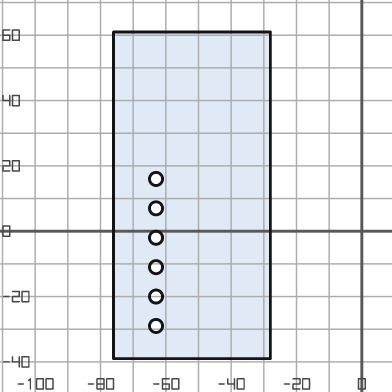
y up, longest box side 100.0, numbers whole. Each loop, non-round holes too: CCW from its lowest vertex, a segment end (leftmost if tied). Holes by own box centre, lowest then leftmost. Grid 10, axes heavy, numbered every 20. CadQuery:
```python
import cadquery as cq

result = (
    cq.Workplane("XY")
    .moveTo(-76.0, -39.0)
    .lineTo(-28.0, -39.0)
    .lineTo(-28.0, 61.0)
    .lineTo(-76.0, 61.0)
    .close()
    .moveTo(-63.0, -29.0)
    .circle(2.0)
    .moveTo(-63.0, -20.0)
    .circle(2.0)
    .moveTo(-63.0, -11.0)
    .circle(2.0)
    .moveTo(-63.0, -2.0)
    .circle(2.0)
    .moveTo(-63.0, 7.0)
    .circle(2.0)
    .moveTo(-63.0, 16.0)
    .circle(2.0)
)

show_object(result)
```